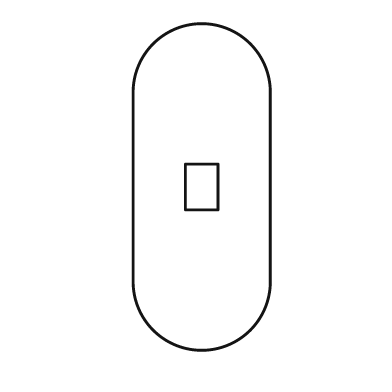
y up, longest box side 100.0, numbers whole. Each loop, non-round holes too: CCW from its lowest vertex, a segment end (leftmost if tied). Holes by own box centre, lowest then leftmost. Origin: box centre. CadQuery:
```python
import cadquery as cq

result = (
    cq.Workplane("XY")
    .moveTo(-21.0, -29.0)
    .threePointArc((0.0, -50.0), (21.0, -29.0))
    .lineTo(21.0, 29.0)
    .threePointArc((0.0, 50.0), (-21.0, 29.0))
    .close()
    .moveTo(-5.0, -7.0)
    .lineTo(5.0, -7.0)
    .lineTo(5.0, 7.0)
    .lineTo(-5.0, 7.0)
    .close()
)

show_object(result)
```